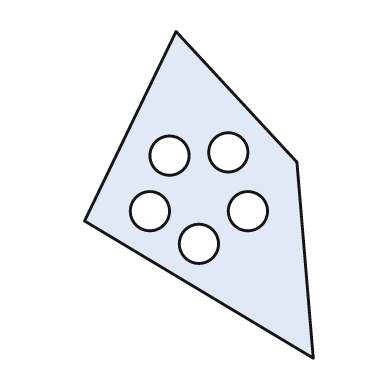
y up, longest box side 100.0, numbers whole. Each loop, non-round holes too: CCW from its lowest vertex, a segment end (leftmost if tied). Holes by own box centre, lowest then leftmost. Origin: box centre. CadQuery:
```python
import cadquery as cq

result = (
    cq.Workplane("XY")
    .moveTo(35.0, -50.0)
    .lineTo(30.0, 10.0)
    .lineTo(-7.0, 50.0)
    .lineTo(-35.0, -8.0)
    .close()
    .moveTo(0.0, -15.0)
    .circle(6.0)
    .moveTo(-15.0, -5.0)
    .circle(6.0)
    .moveTo(15.0, -5.0)
    .circle(6.0)
    .moveTo(-9.0, 12.0)
    .circle(6.0)
    .moveTo(9.0, 13.0)
    .circle(6.0)
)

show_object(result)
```